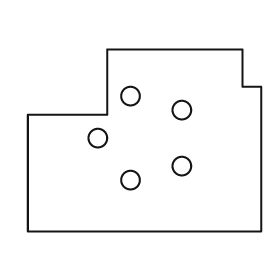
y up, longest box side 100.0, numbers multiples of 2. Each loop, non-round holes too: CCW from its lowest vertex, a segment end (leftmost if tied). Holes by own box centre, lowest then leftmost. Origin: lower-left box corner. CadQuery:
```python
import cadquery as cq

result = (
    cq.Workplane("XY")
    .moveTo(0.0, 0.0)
    .lineTo(100.0, 0.0)
    .lineTo(100.0, 62.0)
    .lineTo(92.0, 62.0)
    .lineTo(92.0, 78.0)
    .lineTo(34.0, 78.0)
    .lineTo(34.0, 50.0)
    .lineTo(0.0, 50.0)
    .close()
    .moveTo(44.0, 22.0)
    .circle(4.0)
    .moveTo(66.0, 28.0)
    .circle(4.0)
    .moveTo(30.0, 40.0)
    .circle(4.0)
    .moveTo(66.0, 52.0)
    .circle(4.0)
    .moveTo(44.0, 58.0)
    .circle(4.0)
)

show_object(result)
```